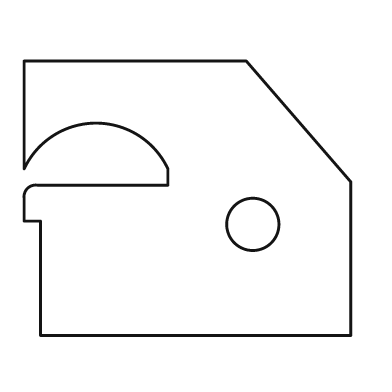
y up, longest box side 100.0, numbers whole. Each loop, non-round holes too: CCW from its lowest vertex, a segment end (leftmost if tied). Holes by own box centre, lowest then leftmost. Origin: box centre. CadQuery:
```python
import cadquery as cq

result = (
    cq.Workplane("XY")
    .moveTo(-45.0, -42.0)
    .lineTo(50.0, -42.0)
    .lineTo(50.0, 5.0)
    .lineTo(18.0, 42.0)
    .lineTo(-50.0, 42.0)
    .lineTo(-50.0, 9.0)
    .threePointArc((-28.0, 23.0), (-6.0, 9.0))
    .lineTo(-6.0, 4.0)
    .lineTo(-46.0, 4.0)
    .threePointArc((-49.0, 3.0), (-50.0, 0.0))
    .lineTo(-50.0, -7.0)
    .lineTo(-45.0, -7.0)
    .close()
    .moveTo(20.0, -8.0)
    .circle(8.0)
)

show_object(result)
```